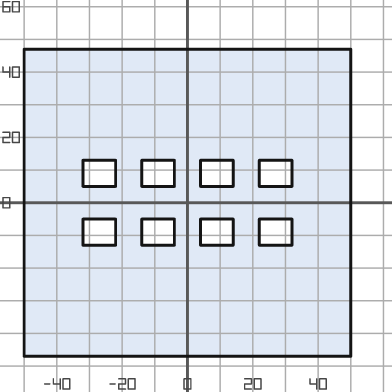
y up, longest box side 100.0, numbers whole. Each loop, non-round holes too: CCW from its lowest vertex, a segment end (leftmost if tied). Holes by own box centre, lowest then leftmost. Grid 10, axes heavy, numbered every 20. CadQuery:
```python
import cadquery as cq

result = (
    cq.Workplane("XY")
    .moveTo(-50.0, -47.0)
    .lineTo(50.0, -47.0)
    .lineTo(50.0, 47.0)
    .lineTo(-50.0, 47.0)
    .close()
    .moveTo(-32.0, -13.0)
    .lineTo(-22.0, -13.0)
    .lineTo(-22.0, -5.0)
    .lineTo(-32.0, -5.0)
    .close()
    .moveTo(-14.0, -13.0)
    .lineTo(-4.0, -13.0)
    .lineTo(-4.0, -5.0)
    .lineTo(-14.0, -5.0)
    .close()
    .moveTo(4.0, -13.0)
    .lineTo(14.0, -13.0)
    .lineTo(14.0, -5.0)
    .lineTo(4.0, -5.0)
    .close()
    .moveTo(22.0, -13.0)
    .lineTo(32.0, -13.0)
    .lineTo(32.0, -5.0)
    .lineTo(22.0, -5.0)
    .close()
    .moveTo(-32.0, 5.0)
    .lineTo(-22.0, 5.0)
    .lineTo(-22.0, 13.0)
    .lineTo(-32.0, 13.0)
    .close()
    .moveTo(-14.0, 5.0)
    .lineTo(-4.0, 5.0)
    .lineTo(-4.0, 13.0)
    .lineTo(-14.0, 13.0)
    .close()
    .moveTo(4.0, 5.0)
    .lineTo(14.0, 5.0)
    .lineTo(14.0, 13.0)
    .lineTo(4.0, 13.0)
    .close()
    .moveTo(22.0, 5.0)
    .lineTo(32.0, 5.0)
    .lineTo(32.0, 13.0)
    .lineTo(22.0, 13.0)
    .close()
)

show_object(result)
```